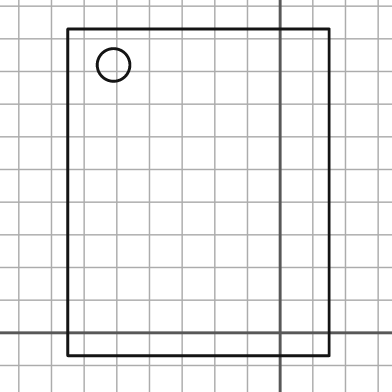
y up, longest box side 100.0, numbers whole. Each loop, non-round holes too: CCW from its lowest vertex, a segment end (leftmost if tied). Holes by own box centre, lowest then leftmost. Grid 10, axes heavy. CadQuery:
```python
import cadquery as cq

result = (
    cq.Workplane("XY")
    .moveTo(-65.0, -7.0)
    .lineTo(15.0, -7.0)
    .lineTo(15.0, 93.0)
    .lineTo(-65.0, 93.0)
    .close()
    .moveTo(-51.0, 82.0)
    .circle(5.0)
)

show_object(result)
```